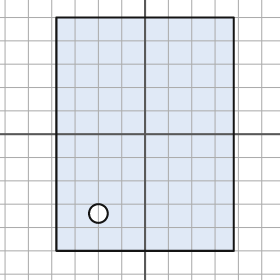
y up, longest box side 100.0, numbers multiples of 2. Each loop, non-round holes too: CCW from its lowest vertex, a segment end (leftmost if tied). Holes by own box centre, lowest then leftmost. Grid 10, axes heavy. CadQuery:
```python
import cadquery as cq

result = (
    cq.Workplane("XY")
    .moveTo(-38.0, -50.0)
    .lineTo(38.0, -50.0)
    .lineTo(38.0, 50.0)
    .lineTo(-38.0, 50.0)
    .close()
    .moveTo(-20.0, -34.0)
    .circle(4.0)
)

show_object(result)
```